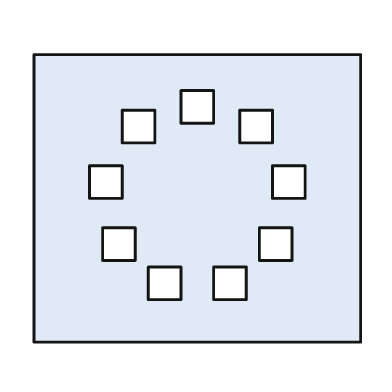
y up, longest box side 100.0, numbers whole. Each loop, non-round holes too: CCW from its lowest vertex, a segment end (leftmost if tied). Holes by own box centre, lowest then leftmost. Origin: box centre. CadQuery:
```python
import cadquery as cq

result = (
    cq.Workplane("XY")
    .moveTo(-50.0, -44.0)
    .lineTo(50.0, -44.0)
    .lineTo(50.0, 44.0)
    .lineTo(-50.0, 44.0)
    .close()
    .moveTo(-15.0, -31.0)
    .lineTo(-5.0, -31.0)
    .lineTo(-5.0, -21.0)
    .lineTo(-15.0, -21.0)
    .close()
    .moveTo(5.0, -31.0)
    .lineTo(15.0, -31.0)
    .lineTo(15.0, -21.0)
    .lineTo(5.0, -21.0)
    .close()
    .moveTo(-29.0, -19.0)
    .lineTo(-19.0, -19.0)
    .lineTo(-19.0, -9.0)
    .lineTo(-29.0, -9.0)
    .close()
    .moveTo(19.0, -19.0)
    .lineTo(29.0, -19.0)
    .lineTo(29.0, -9.0)
    .lineTo(19.0, -9.0)
    .close()
    .moveTo(-33.0, 0.0)
    .lineTo(-23.0, 0.0)
    .lineTo(-23.0, 10.0)
    .lineTo(-33.0, 10.0)
    .close()
    .moveTo(23.0, 0.0)
    .lineTo(33.0, 0.0)
    .lineTo(33.0, 10.0)
    .lineTo(23.0, 10.0)
    .close()
    .moveTo(-23.0, 17.0)
    .lineTo(-13.0, 17.0)
    .lineTo(-13.0, 27.0)
    .lineTo(-23.0, 27.0)
    .close()
    .moveTo(13.0, 17.0)
    .lineTo(23.0, 17.0)
    .lineTo(23.0, 27.0)
    .lineTo(13.0, 27.0)
    .close()
    .moveTo(-5.0, 23.0)
    .lineTo(5.0, 23.0)
    .lineTo(5.0, 33.0)
    .lineTo(-5.0, 33.0)
    .close()
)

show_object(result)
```